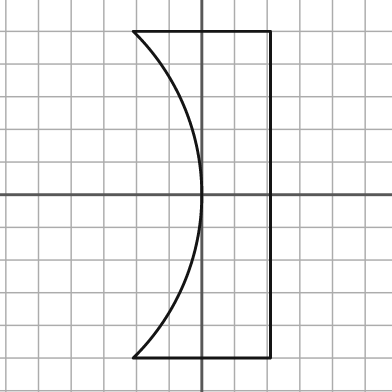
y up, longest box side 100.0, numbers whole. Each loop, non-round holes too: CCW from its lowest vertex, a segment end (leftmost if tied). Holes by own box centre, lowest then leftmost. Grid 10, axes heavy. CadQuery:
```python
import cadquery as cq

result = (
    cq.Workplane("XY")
    .moveTo(-21.0, -50.0)
    .lineTo(21.0, -50.0)
    .lineTo(21.0, 50.0)
    .lineTo(-21.0, 50.0)
    .threePointArc((0.0, 0.0), (-21.0, -50.0))
    .close()
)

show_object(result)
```